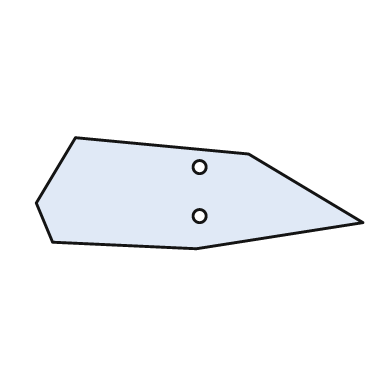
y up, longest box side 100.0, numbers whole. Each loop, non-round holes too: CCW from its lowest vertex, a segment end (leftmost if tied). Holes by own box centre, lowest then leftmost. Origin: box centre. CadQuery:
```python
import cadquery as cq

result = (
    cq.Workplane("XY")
    .moveTo(-1.0, -17.0)
    .lineTo(50.0, -9.0)
    .lineTo(15.0, 12.0)
    .lineTo(-38.0, 17.0)
    .lineTo(-50.0, -3.0)
    .lineTo(-45.0, -15.0)
    .close()
    .moveTo(0.0, -7.0)
    .circle(2.0)
    .moveTo(0.0, 8.0)
    .circle(2.0)
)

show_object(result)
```